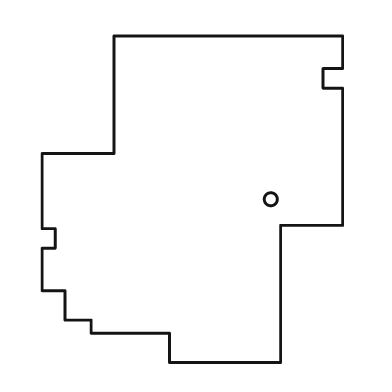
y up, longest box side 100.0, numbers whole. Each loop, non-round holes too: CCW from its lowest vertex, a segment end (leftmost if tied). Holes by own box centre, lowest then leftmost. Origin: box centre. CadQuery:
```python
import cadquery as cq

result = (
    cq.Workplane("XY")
    .moveTo(-7.0, -50.0)
    .lineTo(27.0, -50.0)
    .lineTo(27.0, -8.0)
    .lineTo(46.0, -8.0)
    .lineTo(46.0, 34.0)
    .lineTo(40.0, 34.0)
    .lineTo(40.0, 40.0)
    .lineTo(46.0, 40.0)
    .lineTo(46.0, 50.0)
    .lineTo(-24.0, 50.0)
    .lineTo(-24.0, 14.0)
    .lineTo(-46.0, 14.0)
    .lineTo(-46.0, -9.0)
    .lineTo(-42.0, -9.0)
    .lineTo(-42.0, -15.0)
    .lineTo(-46.0, -15.0)
    .lineTo(-46.0, -28.0)
    .lineTo(-39.0, -28.0)
    .lineTo(-39.0, -37.0)
    .lineTo(-31.0, -37.0)
    .lineTo(-31.0, -41.0)
    .lineTo(-7.0, -41.0)
    .close()
    .moveTo(24.0, 0.0)
    .circle(2.0)
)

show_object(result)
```